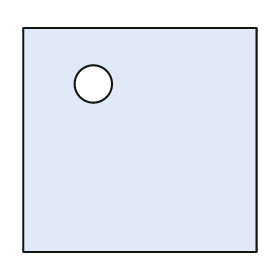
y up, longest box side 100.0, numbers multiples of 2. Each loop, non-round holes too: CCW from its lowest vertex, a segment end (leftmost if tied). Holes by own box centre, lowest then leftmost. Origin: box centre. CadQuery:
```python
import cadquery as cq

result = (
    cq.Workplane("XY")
    .moveTo(-50.0, -48.0)
    .lineTo(50.0, -48.0)
    .lineTo(50.0, 48.0)
    .lineTo(-50.0, 48.0)
    .close()
    .moveTo(-20.0, 24.0)
    .circle(8.0)
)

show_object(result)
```